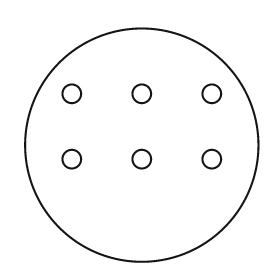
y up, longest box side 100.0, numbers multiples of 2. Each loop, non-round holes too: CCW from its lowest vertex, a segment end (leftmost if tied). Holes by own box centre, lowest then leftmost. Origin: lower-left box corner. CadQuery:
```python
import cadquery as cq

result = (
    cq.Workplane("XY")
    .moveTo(50.0, 50.0)
    .circle(50.0)
    .moveTo(20.0, 44.0)
    .circle(4.0)
    .moveTo(50.0, 44.0)
    .circle(4.0)
    .moveTo(80.0, 44.0)
    .circle(4.0)
    .moveTo(20.0, 72.0)
    .circle(4.0)
    .moveTo(50.0, 72.0)
    .circle(4.0)
    .moveTo(80.0, 72.0)
    .circle(4.0)
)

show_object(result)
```